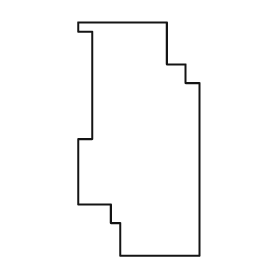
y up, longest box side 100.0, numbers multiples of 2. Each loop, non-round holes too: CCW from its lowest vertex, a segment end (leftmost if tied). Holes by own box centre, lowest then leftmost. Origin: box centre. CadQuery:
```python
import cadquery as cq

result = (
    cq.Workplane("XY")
    .moveTo(-8.0, -50.0)
    .lineTo(26.0, -50.0)
    .lineTo(26.0, 24.0)
    .lineTo(20.0, 24.0)
    .lineTo(20.0, 32.0)
    .lineTo(12.0, 32.0)
    .lineTo(12.0, 50.0)
    .lineTo(-26.0, 50.0)
    .lineTo(-26.0, 46.0)
    .lineTo(-20.0, 46.0)
    .lineTo(-20.0, 0.0)
    .lineTo(-26.0, 0.0)
    .lineTo(-26.0, -28.0)
    .lineTo(-12.0, -28.0)
    .lineTo(-12.0, -36.0)
    .lineTo(-8.0, -36.0)
    .close()
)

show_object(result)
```